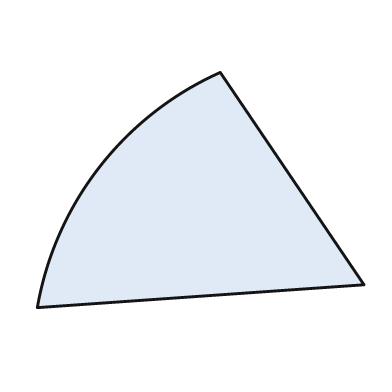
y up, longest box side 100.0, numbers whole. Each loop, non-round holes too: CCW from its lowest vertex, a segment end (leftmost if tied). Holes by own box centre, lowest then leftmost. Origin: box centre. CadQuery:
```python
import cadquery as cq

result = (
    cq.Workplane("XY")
    .moveTo(-50.0, -36.0)
    .lineTo(50.0, -29.0)
    .lineTo(6.0, 36.0)
    .threePointArc((-31.0, 7.0), (-50.0, -36.0))
    .close()
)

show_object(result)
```